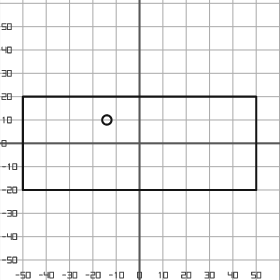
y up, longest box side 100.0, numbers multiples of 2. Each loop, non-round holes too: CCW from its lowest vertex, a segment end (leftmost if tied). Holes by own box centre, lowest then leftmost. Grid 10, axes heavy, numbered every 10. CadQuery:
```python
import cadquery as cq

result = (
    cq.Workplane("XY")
    .moveTo(-50.0, -20.0)
    .lineTo(50.0, -20.0)
    .lineTo(50.0, 20.0)
    .lineTo(-50.0, 20.0)
    .close()
    .moveTo(-14.0, 10.0)
    .circle(2.0)
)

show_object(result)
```